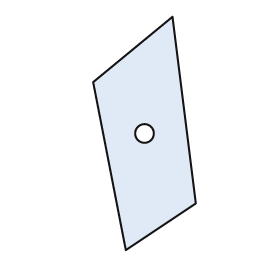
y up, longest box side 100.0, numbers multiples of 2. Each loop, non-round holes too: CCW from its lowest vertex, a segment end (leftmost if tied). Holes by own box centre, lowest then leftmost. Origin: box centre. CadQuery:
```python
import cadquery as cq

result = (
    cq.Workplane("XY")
    .moveTo(-8.0, -50.0)
    .lineTo(22.0, -30.0)
    .lineTo(12.0, 50.0)
    .lineTo(-22.0, 22.0)
    .close()
    .moveTo(0.0, 0.0)
    .circle(4.0)
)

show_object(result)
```